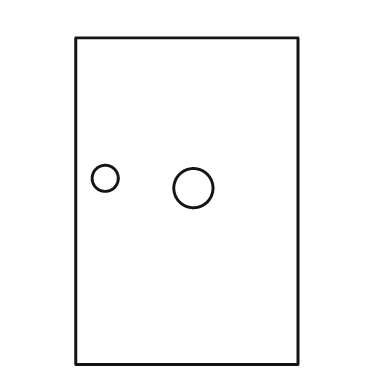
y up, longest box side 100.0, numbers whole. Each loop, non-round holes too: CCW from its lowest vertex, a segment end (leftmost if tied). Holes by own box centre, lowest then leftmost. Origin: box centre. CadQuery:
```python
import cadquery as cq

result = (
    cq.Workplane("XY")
    .moveTo(-34.0, -50.0)
    .lineTo(34.0, -50.0)
    .lineTo(34.0, 50.0)
    .lineTo(-34.0, 50.0)
    .close()
    .moveTo(2.0, 4.0)
    .circle(6.0)
    .moveTo(-25.0, 7.0)
    .circle(4.0)
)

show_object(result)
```